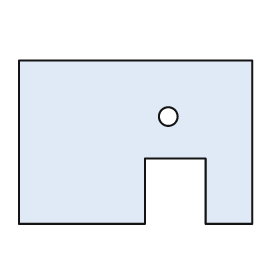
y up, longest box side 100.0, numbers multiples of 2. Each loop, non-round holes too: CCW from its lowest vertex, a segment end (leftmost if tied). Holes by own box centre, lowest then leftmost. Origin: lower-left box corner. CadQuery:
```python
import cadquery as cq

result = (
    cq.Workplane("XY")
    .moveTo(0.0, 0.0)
    .lineTo(54.0, 0.0)
    .lineTo(54.0, 28.0)
    .lineTo(80.0, 28.0)
    .lineTo(80.0, 0.0)
    .lineTo(100.0, 0.0)
    .lineTo(100.0, 70.0)
    .lineTo(0.0, 70.0)
    .close()
    .moveTo(64.0, 46.0)
    .circle(4.0)
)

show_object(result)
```